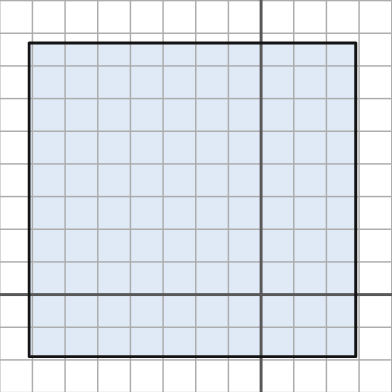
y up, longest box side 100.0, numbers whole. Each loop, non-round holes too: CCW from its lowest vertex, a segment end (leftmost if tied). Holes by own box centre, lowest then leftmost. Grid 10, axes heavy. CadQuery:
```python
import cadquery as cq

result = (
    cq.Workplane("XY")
    .moveTo(-71.0, -19.0)
    .lineTo(29.0, -19.0)
    .lineTo(29.0, 77.0)
    .lineTo(-71.0, 77.0)
    .close()
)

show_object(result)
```